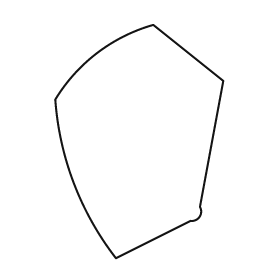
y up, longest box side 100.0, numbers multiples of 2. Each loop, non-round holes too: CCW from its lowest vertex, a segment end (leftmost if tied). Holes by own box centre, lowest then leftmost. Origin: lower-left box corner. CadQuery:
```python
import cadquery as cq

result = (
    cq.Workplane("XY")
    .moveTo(26.0, 0.0)
    .lineTo(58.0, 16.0)
    .threePointArc((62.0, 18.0), (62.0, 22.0))
    .lineTo(72.0, 76.0)
    .lineTo(42.0, 100.0)
    .threePointArc((18.0, 88.0), (0.0, 68.0))
    .threePointArc((8.0, 32.0), (26.0, 0.0))
    .close()
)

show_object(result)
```